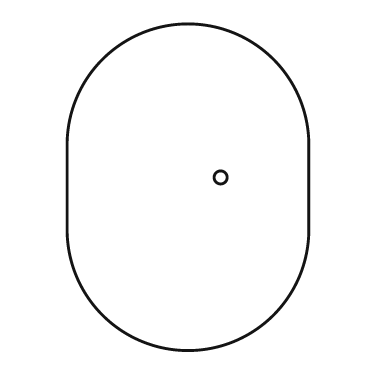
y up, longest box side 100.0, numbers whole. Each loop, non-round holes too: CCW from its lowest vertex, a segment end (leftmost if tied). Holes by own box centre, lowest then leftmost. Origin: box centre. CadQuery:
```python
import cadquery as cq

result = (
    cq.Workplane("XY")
    .moveTo(-37.0, -13.0)
    .threePointArc((0.0, -50.0), (37.0, -13.0))
    .lineTo(37.0, 13.0)
    .threePointArc((0.0, 50.0), (-37.0, 13.0))
    .close()
    .moveTo(10.0, 3.0)
    .circle(2.0)
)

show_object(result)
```